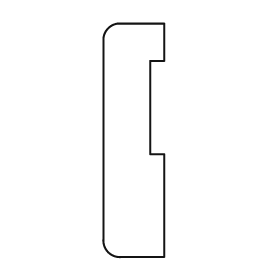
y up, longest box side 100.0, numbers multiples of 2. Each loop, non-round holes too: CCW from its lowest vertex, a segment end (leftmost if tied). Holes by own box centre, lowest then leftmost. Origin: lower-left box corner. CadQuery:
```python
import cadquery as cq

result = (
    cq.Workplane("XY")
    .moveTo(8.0, 0.0)
    .lineTo(26.0, 0.0)
    .lineTo(26.0, 44.0)
    .lineTo(20.0, 44.0)
    .lineTo(20.0, 84.0)
    .lineTo(26.0, 84.0)
    .lineTo(26.0, 100.0)
    .lineTo(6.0, 100.0)
    .threePointArc((2.0, 98.0), (0.0, 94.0))
    .lineTo(0.0, 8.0)
    .threePointArc((2.0, 2.0), (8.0, 0.0))
    .close()
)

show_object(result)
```